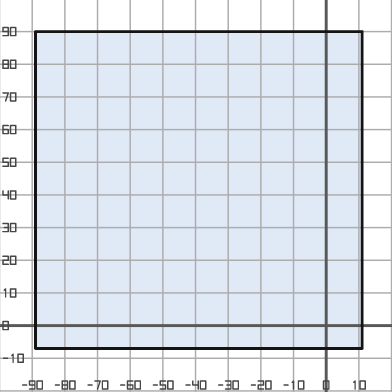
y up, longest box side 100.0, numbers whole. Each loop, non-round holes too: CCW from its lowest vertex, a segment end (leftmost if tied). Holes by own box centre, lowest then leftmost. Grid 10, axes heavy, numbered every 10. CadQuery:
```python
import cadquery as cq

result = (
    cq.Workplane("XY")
    .moveTo(-89.0, -7.0)
    .lineTo(11.0, -7.0)
    .lineTo(11.0, 90.0)
    .lineTo(-89.0, 90.0)
    .close()
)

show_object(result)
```